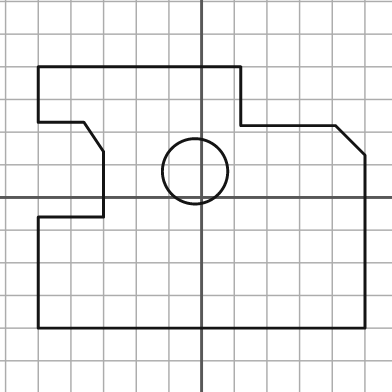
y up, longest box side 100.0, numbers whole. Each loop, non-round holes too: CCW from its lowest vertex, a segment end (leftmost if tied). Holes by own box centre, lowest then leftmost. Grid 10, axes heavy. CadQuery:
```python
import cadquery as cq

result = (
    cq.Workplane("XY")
    .moveTo(-50.0, -40.0)
    .lineTo(50.0, -40.0)
    .lineTo(50.0, 13.0)
    .lineTo(41.0, 22.0)
    .lineTo(12.0, 22.0)
    .lineTo(12.0, 40.0)
    .lineTo(-50.0, 40.0)
    .lineTo(-50.0, 23.0)
    .lineTo(-36.0, 23.0)
    .lineTo(-30.0, 14.0)
    .lineTo(-30.0, -6.0)
    .lineTo(-50.0, -6.0)
    .close()
    .moveTo(-2.0, 8.0)
    .circle(10.0)
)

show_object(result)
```